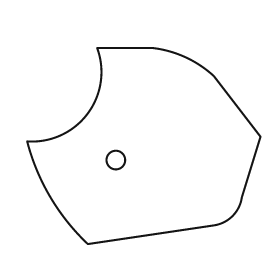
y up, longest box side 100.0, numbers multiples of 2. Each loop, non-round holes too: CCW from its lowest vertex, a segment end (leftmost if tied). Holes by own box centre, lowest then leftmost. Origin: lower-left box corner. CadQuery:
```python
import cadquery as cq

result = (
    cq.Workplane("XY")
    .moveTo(26.0, 0.0)
    .lineTo(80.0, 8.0)
    .threePointArc((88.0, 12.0), (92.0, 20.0))
    .lineTo(100.0, 46.0)
    .lineTo(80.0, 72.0)
    .threePointArc((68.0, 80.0), (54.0, 84.0))
    .lineTo(30.0, 84.0)
    .threePointArc((26.0, 56.0), (0.0, 44.0))
    .threePointArc((10.0, 20.0), (26.0, 0.0))
    .close()
    .moveTo(38.0, 36.0)
    .circle(4.0)
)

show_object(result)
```